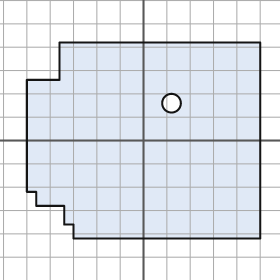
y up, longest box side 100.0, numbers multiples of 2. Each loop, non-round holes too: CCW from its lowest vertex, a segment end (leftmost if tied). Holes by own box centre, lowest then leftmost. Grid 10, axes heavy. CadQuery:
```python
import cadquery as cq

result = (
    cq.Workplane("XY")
    .moveTo(-30.0, -42.0)
    .lineTo(50.0, -42.0)
    .lineTo(50.0, 42.0)
    .lineTo(-36.0, 42.0)
    .lineTo(-36.0, 26.0)
    .lineTo(-50.0, 26.0)
    .lineTo(-50.0, -22.0)
    .lineTo(-46.0, -22.0)
    .lineTo(-46.0, -28.0)
    .lineTo(-34.0, -28.0)
    .lineTo(-34.0, -36.0)
    .lineTo(-30.0, -36.0)
    .close()
    .moveTo(12.0, 16.0)
    .circle(4.0)
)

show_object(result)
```